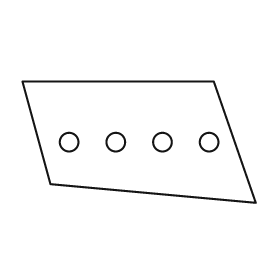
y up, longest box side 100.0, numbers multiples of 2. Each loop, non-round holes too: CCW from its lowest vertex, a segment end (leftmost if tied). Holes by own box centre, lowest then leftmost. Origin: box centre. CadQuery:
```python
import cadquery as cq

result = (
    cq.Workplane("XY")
    .moveTo(50.0, -26.0)
    .lineTo(32.0, 26.0)
    .lineTo(-50.0, 26.0)
    .lineTo(-38.0, -18.0)
    .close()
    .moveTo(-30.0, 0.0)
    .circle(4.0)
    .moveTo(-10.0, 0.0)
    .circle(4.0)
    .moveTo(10.0, 0.0)
    .circle(4.0)
    .moveTo(30.0, 0.0)
    .circle(4.0)
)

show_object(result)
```